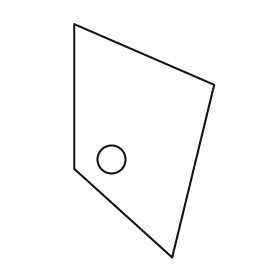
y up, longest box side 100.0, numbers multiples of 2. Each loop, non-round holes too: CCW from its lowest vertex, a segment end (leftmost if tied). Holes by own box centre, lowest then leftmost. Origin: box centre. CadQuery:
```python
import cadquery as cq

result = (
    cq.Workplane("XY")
    .moveTo(12.0, -50.0)
    .lineTo(30.0, 24.0)
    .lineTo(-30.0, 50.0)
    .lineTo(-30.0, -12.0)
    .close()
    .moveTo(-14.0, -8.0)
    .circle(6.0)
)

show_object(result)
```